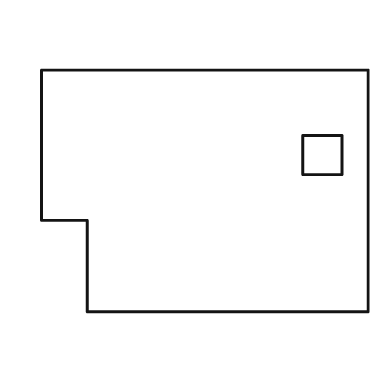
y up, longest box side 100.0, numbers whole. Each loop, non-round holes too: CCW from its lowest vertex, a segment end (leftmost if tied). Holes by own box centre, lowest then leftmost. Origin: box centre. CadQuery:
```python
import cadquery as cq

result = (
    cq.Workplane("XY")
    .moveTo(-36.0, -37.0)
    .lineTo(50.0, -37.0)
    .lineTo(50.0, 37.0)
    .lineTo(-50.0, 37.0)
    .lineTo(-50.0, -9.0)
    .lineTo(-36.0, -9.0)
    .close()
    .moveTo(30.0, 5.0)
    .lineTo(42.0, 5.0)
    .lineTo(42.0, 17.0)
    .lineTo(30.0, 17.0)
    .close()
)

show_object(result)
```